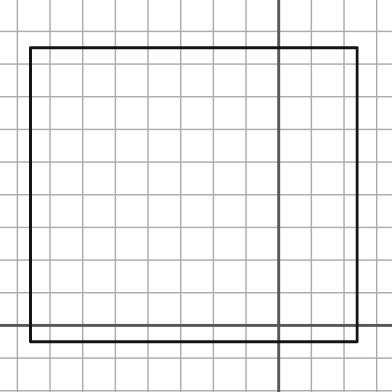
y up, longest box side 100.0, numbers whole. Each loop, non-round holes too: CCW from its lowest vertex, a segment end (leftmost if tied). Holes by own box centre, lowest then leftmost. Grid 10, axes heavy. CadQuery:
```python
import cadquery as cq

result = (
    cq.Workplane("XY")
    .moveTo(-76.0, -5.0)
    .lineTo(24.0, -5.0)
    .lineTo(24.0, 85.0)
    .lineTo(-76.0, 85.0)
    .close()
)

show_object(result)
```